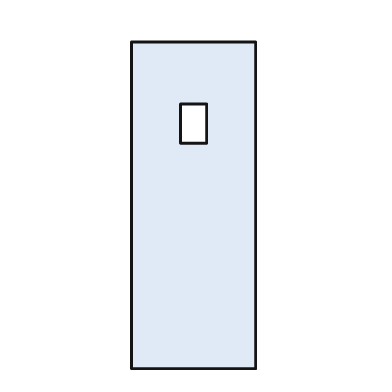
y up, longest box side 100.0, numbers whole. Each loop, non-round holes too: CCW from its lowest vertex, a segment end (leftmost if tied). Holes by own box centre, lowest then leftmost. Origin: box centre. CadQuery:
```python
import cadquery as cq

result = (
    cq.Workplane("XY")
    .moveTo(-19.0, -50.0)
    .lineTo(19.0, -50.0)
    .lineTo(19.0, 50.0)
    .lineTo(-19.0, 50.0)
    .close()
    .moveTo(-4.0, 19.0)
    .lineTo(4.0, 19.0)
    .lineTo(4.0, 31.0)
    .lineTo(-4.0, 31.0)
    .close()
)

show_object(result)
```